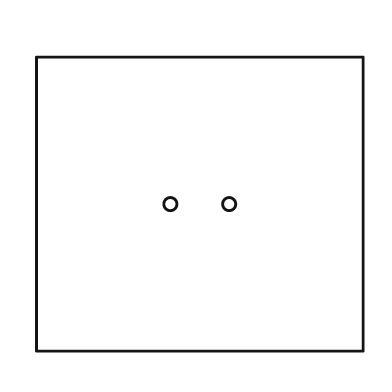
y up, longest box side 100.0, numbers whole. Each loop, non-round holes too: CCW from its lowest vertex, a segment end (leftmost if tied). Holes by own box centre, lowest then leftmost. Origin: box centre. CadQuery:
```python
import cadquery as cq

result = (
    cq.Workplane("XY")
    .moveTo(-50.0, -45.0)
    .lineTo(50.0, -45.0)
    .lineTo(50.0, 45.0)
    .lineTo(-50.0, 45.0)
    .close()
    .moveTo(-9.0, 0.0)
    .circle(2.0)
    .moveTo(9.0, 0.0)
    .circle(2.0)
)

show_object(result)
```